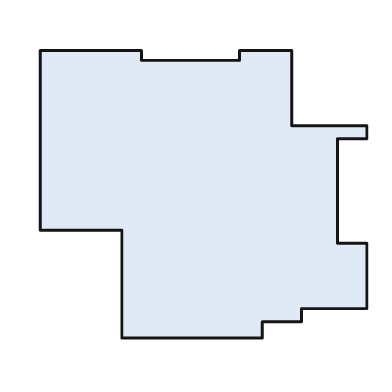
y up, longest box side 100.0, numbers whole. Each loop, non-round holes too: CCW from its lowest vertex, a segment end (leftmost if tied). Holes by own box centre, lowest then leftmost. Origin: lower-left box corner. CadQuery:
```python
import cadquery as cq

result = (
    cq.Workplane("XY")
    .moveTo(25.0, 0.0)
    .lineTo(68.0, 0.0)
    .lineTo(68.0, 5.0)
    .lineTo(80.0, 5.0)
    .lineTo(80.0, 9.0)
    .lineTo(100.0, 9.0)
    .lineTo(100.0, 29.0)
    .lineTo(91.0, 29.0)
    .lineTo(91.0, 61.0)
    .lineTo(100.0, 61.0)
    .lineTo(100.0, 65.0)
    .lineTo(77.0, 65.0)
    .lineTo(77.0, 88.0)
    .lineTo(61.0, 88.0)
    .lineTo(61.0, 85.0)
    .lineTo(31.0, 85.0)
    .lineTo(31.0, 88.0)
    .lineTo(0.0, 88.0)
    .lineTo(0.0, 33.0)
    .lineTo(25.0, 33.0)
    .close()
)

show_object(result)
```